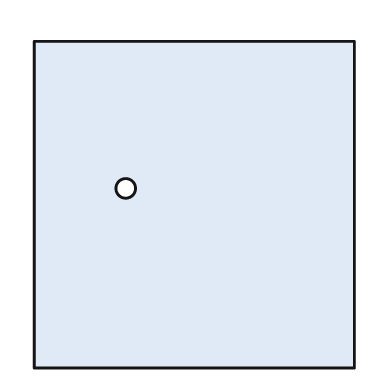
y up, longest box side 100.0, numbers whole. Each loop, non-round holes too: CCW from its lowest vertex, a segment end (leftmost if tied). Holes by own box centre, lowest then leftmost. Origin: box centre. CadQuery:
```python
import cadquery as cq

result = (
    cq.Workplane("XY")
    .moveTo(-49.0, -50.0)
    .lineTo(49.0, -50.0)
    .lineTo(49.0, 50.0)
    .lineTo(-49.0, 50.0)
    .close()
    .moveTo(-21.0, 5.0)
    .circle(3.0)
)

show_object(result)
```